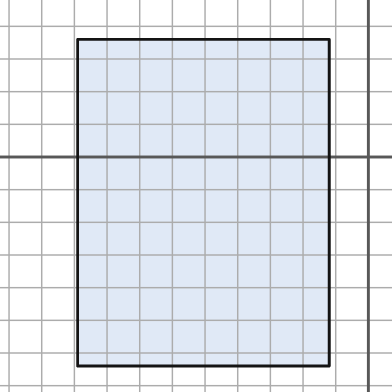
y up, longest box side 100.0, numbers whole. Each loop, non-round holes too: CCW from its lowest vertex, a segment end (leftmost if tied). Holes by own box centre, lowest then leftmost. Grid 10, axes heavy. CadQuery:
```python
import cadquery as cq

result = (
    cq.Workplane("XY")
    .moveTo(-89.0, -64.0)
    .lineTo(-12.0, -64.0)
    .lineTo(-12.0, 36.0)
    .lineTo(-89.0, 36.0)
    .close()
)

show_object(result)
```